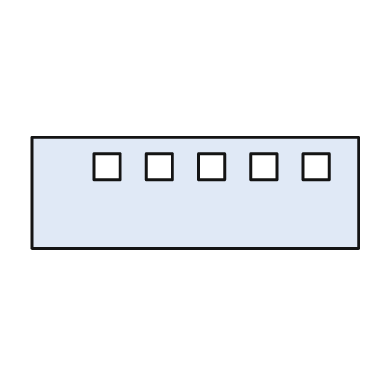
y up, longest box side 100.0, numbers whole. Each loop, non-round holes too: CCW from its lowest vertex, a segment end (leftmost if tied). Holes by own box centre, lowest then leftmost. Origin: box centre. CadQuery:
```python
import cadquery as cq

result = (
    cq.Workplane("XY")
    .moveTo(-50.0, -17.0)
    .lineTo(50.0, -17.0)
    .lineTo(50.0, 17.0)
    .lineTo(-50.0, 17.0)
    .close()
    .moveTo(-31.0, 4.0)
    .lineTo(-23.0, 4.0)
    .lineTo(-23.0, 12.0)
    .lineTo(-31.0, 12.0)
    .close()
    .moveTo(-15.0, 4.0)
    .lineTo(-7.0, 4.0)
    .lineTo(-7.0, 12.0)
    .lineTo(-15.0, 12.0)
    .close()
    .moveTo(1.0, 4.0)
    .lineTo(9.0, 4.0)
    .lineTo(9.0, 12.0)
    .lineTo(1.0, 12.0)
    .close()
    .moveTo(17.0, 4.0)
    .lineTo(25.0, 4.0)
    .lineTo(25.0, 12.0)
    .lineTo(17.0, 12.0)
    .close()
    .moveTo(33.0, 4.0)
    .lineTo(41.0, 4.0)
    .lineTo(41.0, 12.0)
    .lineTo(33.0, 12.0)
    .close()
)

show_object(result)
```